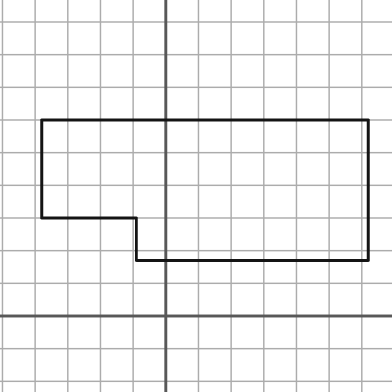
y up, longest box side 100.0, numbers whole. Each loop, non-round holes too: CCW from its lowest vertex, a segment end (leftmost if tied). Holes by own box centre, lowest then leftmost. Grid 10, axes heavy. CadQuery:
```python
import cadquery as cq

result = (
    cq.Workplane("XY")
    .moveTo(-9.0, 17.0)
    .lineTo(62.0, 17.0)
    .lineTo(62.0, 60.0)
    .lineTo(-38.0, 60.0)
    .lineTo(-38.0, 30.0)
    .lineTo(-9.0, 30.0)
    .close()
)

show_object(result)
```